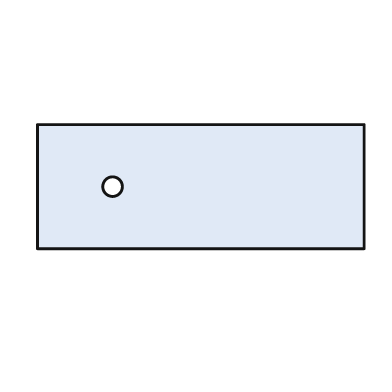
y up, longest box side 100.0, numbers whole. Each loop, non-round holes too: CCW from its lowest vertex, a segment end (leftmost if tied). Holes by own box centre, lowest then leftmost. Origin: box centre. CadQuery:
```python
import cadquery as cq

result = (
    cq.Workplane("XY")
    .moveTo(-50.0, -19.0)
    .lineTo(50.0, -19.0)
    .lineTo(50.0, 19.0)
    .lineTo(-50.0, 19.0)
    .close()
    .moveTo(-27.0, 0.0)
    .circle(3.0)
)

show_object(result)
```